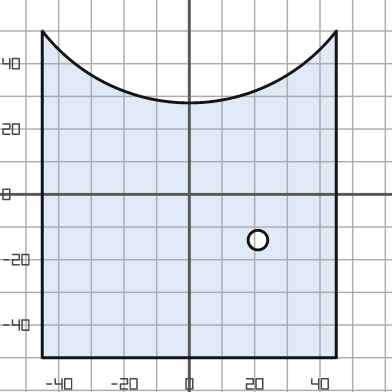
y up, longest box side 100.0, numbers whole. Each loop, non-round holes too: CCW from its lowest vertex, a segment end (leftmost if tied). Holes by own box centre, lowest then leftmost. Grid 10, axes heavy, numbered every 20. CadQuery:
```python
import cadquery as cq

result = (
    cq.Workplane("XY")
    .moveTo(-45.0, -50.0)
    .lineTo(45.0, -50.0)
    .lineTo(45.0, 50.0)
    .threePointArc((0.0, 28.0), (-45.0, 50.0))
    .close()
    .moveTo(21.0, -14.0)
    .circle(3.0)
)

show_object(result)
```